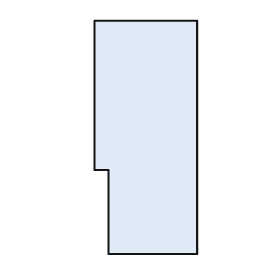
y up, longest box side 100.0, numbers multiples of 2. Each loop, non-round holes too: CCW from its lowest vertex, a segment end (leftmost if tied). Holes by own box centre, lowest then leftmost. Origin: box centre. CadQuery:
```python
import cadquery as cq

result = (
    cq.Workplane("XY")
    .moveTo(-16.0, -50.0)
    .lineTo(22.0, -50.0)
    .lineTo(22.0, 50.0)
    .lineTo(-22.0, 50.0)
    .lineTo(-22.0, -14.0)
    .lineTo(-16.0, -14.0)
    .close()
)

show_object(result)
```